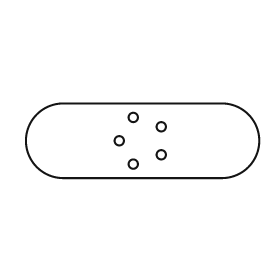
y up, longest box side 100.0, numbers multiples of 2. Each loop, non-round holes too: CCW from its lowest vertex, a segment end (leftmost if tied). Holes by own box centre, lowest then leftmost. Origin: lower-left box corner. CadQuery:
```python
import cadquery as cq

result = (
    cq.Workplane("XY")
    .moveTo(16.0, 0.0)
    .lineTo(84.0, 0.0)
    .threePointArc((100.0, 16.0), (84.0, 32.0))
    .lineTo(16.0, 32.0)
    .threePointArc((0.0, 16.0), (16.0, 0.0))
    .close()
    .moveTo(46.0, 6.0)
    .circle(2.0)
    .moveTo(58.0, 10.0)
    .circle(2.0)
    .moveTo(40.0, 16.0)
    .circle(2.0)
    .moveTo(58.0, 22.0)
    .circle(2.0)
    .moveTo(46.0, 26.0)
    .circle(2.0)
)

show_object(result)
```